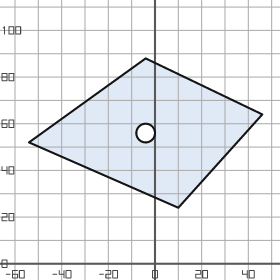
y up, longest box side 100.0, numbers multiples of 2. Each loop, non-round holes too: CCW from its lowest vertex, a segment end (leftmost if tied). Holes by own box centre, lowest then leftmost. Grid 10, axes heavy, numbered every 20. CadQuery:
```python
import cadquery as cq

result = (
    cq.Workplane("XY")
    .moveTo(10.0, 24.0)
    .lineTo(46.0, 64.0)
    .lineTo(-4.0, 88.0)
    .lineTo(-54.0, 52.0)
    .close()
    .moveTo(-4.0, 56.0)
    .circle(4.0)
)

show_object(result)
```